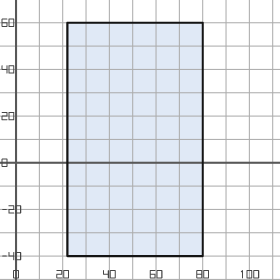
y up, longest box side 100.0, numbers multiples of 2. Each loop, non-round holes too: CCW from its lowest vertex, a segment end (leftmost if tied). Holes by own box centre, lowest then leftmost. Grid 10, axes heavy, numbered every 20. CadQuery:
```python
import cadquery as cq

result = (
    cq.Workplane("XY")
    .moveTo(22.0, -40.0)
    .lineTo(80.0, -40.0)
    .lineTo(80.0, 60.0)
    .lineTo(22.0, 60.0)
    .close()
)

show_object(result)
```